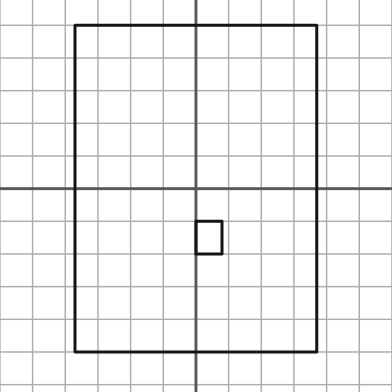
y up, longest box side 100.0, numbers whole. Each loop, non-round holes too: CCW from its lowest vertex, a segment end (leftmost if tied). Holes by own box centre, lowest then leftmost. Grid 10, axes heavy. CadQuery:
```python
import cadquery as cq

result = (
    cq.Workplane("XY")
    .moveTo(-37.0, -50.0)
    .lineTo(37.0, -50.0)
    .lineTo(37.0, 50.0)
    .lineTo(-37.0, 50.0)
    .close()
    .moveTo(0.0, -20.0)
    .lineTo(8.0, -20.0)
    .lineTo(8.0, -10.0)
    .lineTo(0.0, -10.0)
    .close()
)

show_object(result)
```